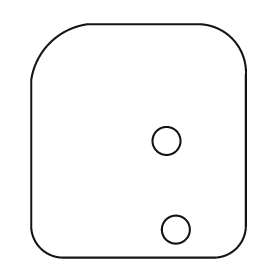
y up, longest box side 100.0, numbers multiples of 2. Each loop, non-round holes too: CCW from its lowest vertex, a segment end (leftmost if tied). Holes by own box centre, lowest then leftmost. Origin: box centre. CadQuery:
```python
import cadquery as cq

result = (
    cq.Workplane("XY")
    .moveTo(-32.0, -50.0)
    .lineTo(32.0, -50.0)
    .threePointArc((42.0, -46.0), (46.0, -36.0))
    .lineTo(46.0, 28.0)
    .threePointArc((40.0, 44.0), (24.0, 50.0))
    .lineTo(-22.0, 50.0)
    .threePointArc((-38.0, 42.0), (-46.0, 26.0))
    .lineTo(-46.0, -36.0)
    .threePointArc((-42.0, -46.0), (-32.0, -50.0))
    .close()
    .moveTo(16.0, -38.0)
    .circle(6.0)
    .moveTo(12.0, 0.0)
    .circle(6.0)
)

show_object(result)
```